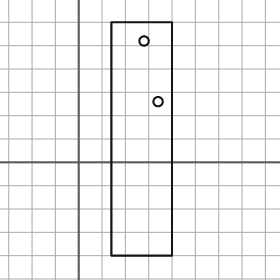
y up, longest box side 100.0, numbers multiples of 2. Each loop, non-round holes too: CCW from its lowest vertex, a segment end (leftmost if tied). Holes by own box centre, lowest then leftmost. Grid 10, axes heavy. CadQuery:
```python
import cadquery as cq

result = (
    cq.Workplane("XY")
    .moveTo(14.0, -40.0)
    .lineTo(40.0, -40.0)
    .lineTo(40.0, 60.0)
    .lineTo(14.0, 60.0)
    .close()
    .moveTo(34.0, 26.0)
    .circle(2.0)
    .moveTo(28.0, 52.0)
    .circle(2.0)
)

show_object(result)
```